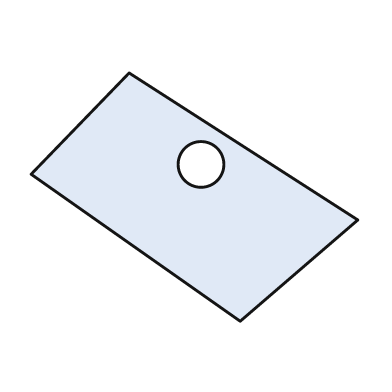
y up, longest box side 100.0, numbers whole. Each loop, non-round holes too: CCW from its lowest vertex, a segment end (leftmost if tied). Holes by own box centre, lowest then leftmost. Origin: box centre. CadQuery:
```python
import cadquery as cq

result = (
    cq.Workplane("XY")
    .moveTo(14.0, -38.0)
    .lineTo(50.0, -7.0)
    .lineTo(-20.0, 38.0)
    .lineTo(-50.0, 7.0)
    .close()
    .moveTo(2.0, 10.0)
    .circle(7.0)
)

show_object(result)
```